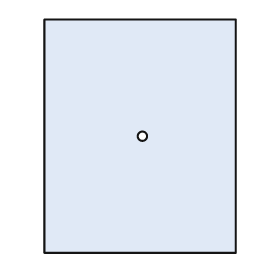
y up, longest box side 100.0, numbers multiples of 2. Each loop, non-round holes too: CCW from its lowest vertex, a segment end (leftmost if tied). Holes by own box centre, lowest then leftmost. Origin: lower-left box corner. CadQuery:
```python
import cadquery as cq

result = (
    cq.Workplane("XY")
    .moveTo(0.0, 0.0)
    .lineTo(82.0, 0.0)
    .lineTo(82.0, 100.0)
    .lineTo(0.0, 100.0)
    .close()
    .moveTo(42.0, 50.0)
    .circle(2.0)
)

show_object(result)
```